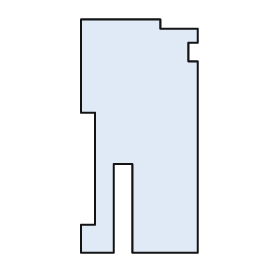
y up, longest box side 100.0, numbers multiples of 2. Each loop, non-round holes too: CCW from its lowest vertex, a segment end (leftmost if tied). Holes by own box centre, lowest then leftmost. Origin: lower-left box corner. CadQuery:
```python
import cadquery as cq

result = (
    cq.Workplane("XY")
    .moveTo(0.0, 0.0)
    .lineTo(14.0, 0.0)
    .lineTo(14.0, 38.0)
    .lineTo(22.0, 38.0)
    .lineTo(22.0, 0.0)
    .lineTo(50.0, 0.0)
    .lineTo(50.0, 82.0)
    .lineTo(46.0, 82.0)
    .lineTo(46.0, 90.0)
    .lineTo(50.0, 90.0)
    .lineTo(50.0, 96.0)
    .lineTo(34.0, 96.0)
    .lineTo(34.0, 100.0)
    .lineTo(0.0, 100.0)
    .lineTo(0.0, 60.0)
    .lineTo(6.0, 60.0)
    .lineTo(6.0, 12.0)
    .lineTo(0.0, 12.0)
    .close()
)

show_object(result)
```